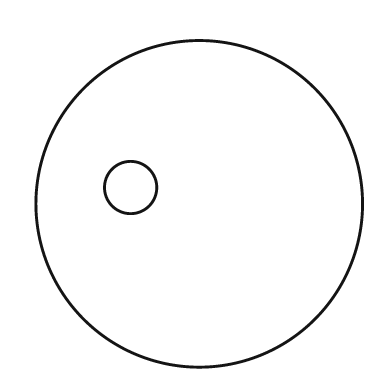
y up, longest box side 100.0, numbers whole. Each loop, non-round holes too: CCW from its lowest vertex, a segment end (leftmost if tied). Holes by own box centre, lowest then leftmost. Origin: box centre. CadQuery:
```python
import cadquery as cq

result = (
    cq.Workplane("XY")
    .moveTo(0.0, 0.0)
    .circle(50.0)
    .moveTo(-21.0, 5.0)
    .circle(8.0)
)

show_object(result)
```